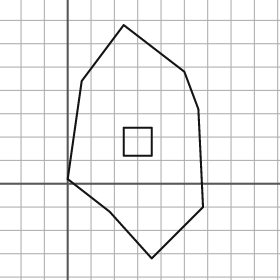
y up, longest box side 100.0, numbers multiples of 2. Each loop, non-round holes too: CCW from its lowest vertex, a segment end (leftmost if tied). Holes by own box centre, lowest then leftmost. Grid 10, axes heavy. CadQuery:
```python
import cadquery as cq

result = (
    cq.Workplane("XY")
    .moveTo(36.0, -32.0)
    .lineTo(58.0, -10.0)
    .lineTo(56.0, 32.0)
    .lineTo(50.0, 48.0)
    .lineTo(24.0, 68.0)
    .lineTo(6.0, 44.0)
    .lineTo(0.0, 2.0)
    .lineTo(18.0, -12.0)
    .close()
    .moveTo(24.0, 12.0)
    .lineTo(36.0, 12.0)
    .lineTo(36.0, 24.0)
    .lineTo(24.0, 24.0)
    .close()
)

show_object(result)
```